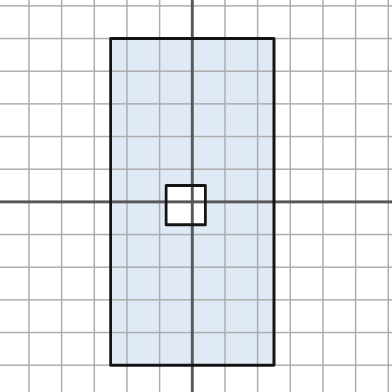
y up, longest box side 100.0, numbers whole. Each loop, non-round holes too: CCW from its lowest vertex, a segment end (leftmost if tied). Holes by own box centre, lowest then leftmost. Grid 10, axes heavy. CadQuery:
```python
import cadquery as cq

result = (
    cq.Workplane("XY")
    .moveTo(-25.0, -50.0)
    .lineTo(25.0, -50.0)
    .lineTo(25.0, 50.0)
    .lineTo(-25.0, 50.0)
    .close()
    .moveTo(-8.0, -7.0)
    .lineTo(4.0, -7.0)
    .lineTo(4.0, 5.0)
    .lineTo(-8.0, 5.0)
    .close()
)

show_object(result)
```